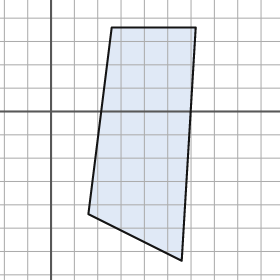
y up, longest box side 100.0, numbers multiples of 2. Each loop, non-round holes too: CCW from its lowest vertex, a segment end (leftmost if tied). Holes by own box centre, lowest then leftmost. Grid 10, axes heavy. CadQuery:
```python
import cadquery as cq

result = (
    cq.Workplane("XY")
    .moveTo(56.0, -64.0)
    .lineTo(62.0, 36.0)
    .lineTo(26.0, 36.0)
    .lineTo(16.0, -44.0)
    .close()
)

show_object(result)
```